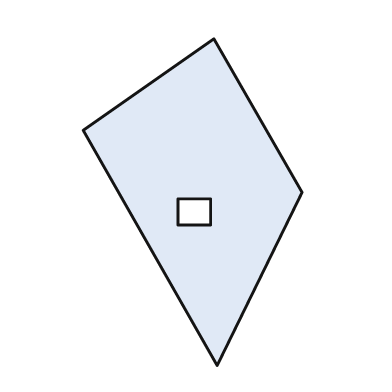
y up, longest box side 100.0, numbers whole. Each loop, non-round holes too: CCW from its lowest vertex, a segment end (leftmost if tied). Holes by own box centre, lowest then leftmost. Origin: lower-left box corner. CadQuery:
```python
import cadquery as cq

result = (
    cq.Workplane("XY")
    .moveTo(41.0, 0.0)
    .lineTo(67.0, 53.0)
    .lineTo(40.0, 100.0)
    .lineTo(0.0, 72.0)
    .close()
    .moveTo(29.0, 43.0)
    .lineTo(39.0, 43.0)
    .lineTo(39.0, 51.0)
    .lineTo(29.0, 51.0)
    .close()
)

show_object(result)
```